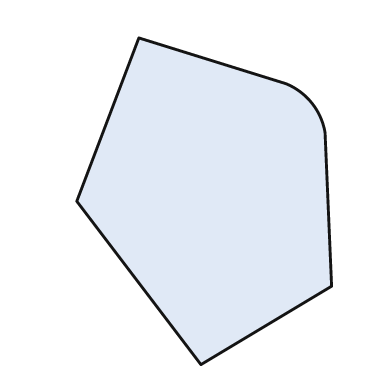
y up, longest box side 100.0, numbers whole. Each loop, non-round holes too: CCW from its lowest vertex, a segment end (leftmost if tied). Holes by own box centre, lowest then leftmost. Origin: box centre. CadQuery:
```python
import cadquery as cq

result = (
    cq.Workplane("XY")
    .moveTo(-1.0, -50.0)
    .lineTo(39.0, -26.0)
    .lineTo(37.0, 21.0)
    .threePointArc((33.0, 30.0), (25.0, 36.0))
    .lineTo(-20.0, 50.0)
    .lineTo(-39.0, 0.0)
    .close()
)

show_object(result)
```